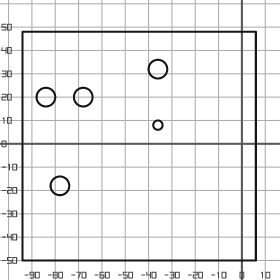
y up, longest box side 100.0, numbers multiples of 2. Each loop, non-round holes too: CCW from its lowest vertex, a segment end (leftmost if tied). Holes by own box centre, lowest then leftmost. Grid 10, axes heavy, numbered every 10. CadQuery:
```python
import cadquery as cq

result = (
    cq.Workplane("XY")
    .moveTo(-94.0, -50.0)
    .lineTo(6.0, -50.0)
    .lineTo(6.0, 48.0)
    .lineTo(-94.0, 48.0)
    .close()
    .moveTo(-78.0, -18.0)
    .circle(4.0)
    .moveTo(-36.0, 8.0)
    .circle(2.0)
    .moveTo(-84.0, 20.0)
    .circle(4.0)
    .moveTo(-68.0, 20.0)
    .circle(4.0)
    .moveTo(-36.0, 32.0)
    .circle(4.0)
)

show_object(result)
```